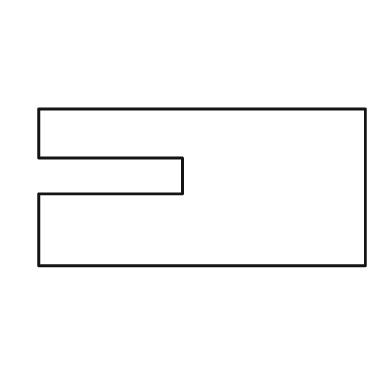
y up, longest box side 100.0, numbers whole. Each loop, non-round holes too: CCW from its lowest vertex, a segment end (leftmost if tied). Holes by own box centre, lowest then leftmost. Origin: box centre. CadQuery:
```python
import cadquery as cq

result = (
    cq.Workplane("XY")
    .moveTo(-50.0, -24.0)
    .lineTo(50.0, -24.0)
    .lineTo(50.0, 24.0)
    .lineTo(-50.0, 24.0)
    .lineTo(-50.0, 9.0)
    .lineTo(-6.0, 9.0)
    .lineTo(-6.0, -2.0)
    .lineTo(-50.0, -2.0)
    .close()
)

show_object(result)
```